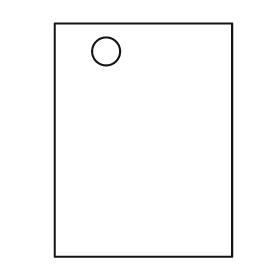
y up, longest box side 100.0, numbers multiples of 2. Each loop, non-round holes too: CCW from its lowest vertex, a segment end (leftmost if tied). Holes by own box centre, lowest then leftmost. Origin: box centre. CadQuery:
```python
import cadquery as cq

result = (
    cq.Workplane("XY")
    .moveTo(-38.0, -50.0)
    .lineTo(38.0, -50.0)
    .lineTo(38.0, 50.0)
    .lineTo(-38.0, 50.0)
    .close()
    .moveTo(-16.0, 38.0)
    .circle(6.0)
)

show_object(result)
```